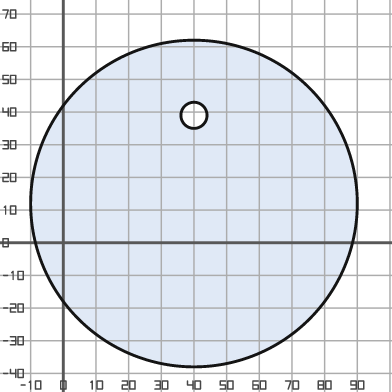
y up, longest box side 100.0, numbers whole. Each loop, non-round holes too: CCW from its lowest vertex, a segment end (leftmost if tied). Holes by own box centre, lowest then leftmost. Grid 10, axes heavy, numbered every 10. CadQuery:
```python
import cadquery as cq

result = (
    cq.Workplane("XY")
    .moveTo(40.0, 12.0)
    .circle(50.0)
    .moveTo(40.0, 39.0)
    .circle(4.0)
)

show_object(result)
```